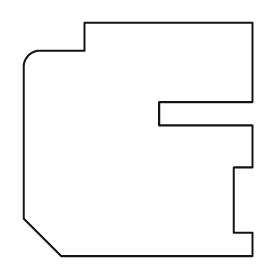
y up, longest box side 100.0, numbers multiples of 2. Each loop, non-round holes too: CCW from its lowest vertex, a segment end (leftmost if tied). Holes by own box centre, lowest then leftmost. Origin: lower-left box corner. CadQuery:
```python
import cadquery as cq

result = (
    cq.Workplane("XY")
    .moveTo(16.0, 0.0)
    .lineTo(98.0, 0.0)
    .lineTo(98.0, 10.0)
    .lineTo(90.0, 10.0)
    .lineTo(90.0, 38.0)
    .lineTo(98.0, 38.0)
    .lineTo(98.0, 56.0)
    .lineTo(58.0, 56.0)
    .lineTo(58.0, 66.0)
    .lineTo(98.0, 66.0)
    .lineTo(98.0, 100.0)
    .lineTo(26.0, 100.0)
    .lineTo(26.0, 88.0)
    .lineTo(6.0, 88.0)
    .threePointArc((2.0, 86.0), (0.0, 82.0))
    .lineTo(0.0, 16.0)
    .close()
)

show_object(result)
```